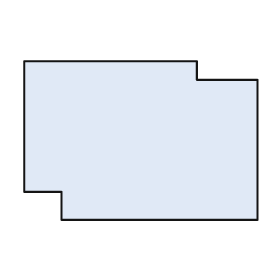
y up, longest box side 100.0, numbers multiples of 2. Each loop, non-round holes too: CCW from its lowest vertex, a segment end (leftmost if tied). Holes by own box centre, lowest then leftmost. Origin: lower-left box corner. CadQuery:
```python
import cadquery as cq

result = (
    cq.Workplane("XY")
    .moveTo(16.0, 0.0)
    .lineTo(100.0, 0.0)
    .lineTo(100.0, 60.0)
    .lineTo(74.0, 60.0)
    .lineTo(74.0, 68.0)
    .lineTo(0.0, 68.0)
    .lineTo(0.0, 12.0)
    .lineTo(16.0, 12.0)
    .close()
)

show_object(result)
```